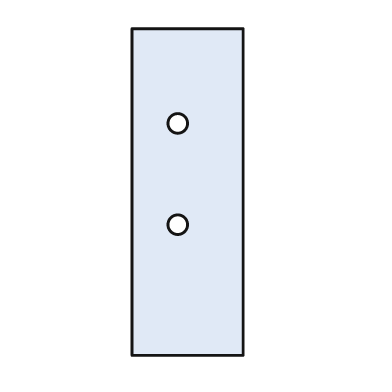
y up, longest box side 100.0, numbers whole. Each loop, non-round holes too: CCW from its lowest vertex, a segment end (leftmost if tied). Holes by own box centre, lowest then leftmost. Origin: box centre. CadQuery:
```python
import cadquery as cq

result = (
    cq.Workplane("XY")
    .moveTo(-17.0, -50.0)
    .lineTo(17.0, -50.0)
    .lineTo(17.0, 50.0)
    .lineTo(-17.0, 50.0)
    .close()
    .moveTo(-3.0, -10.0)
    .circle(3.0)
    .moveTo(-3.0, 21.0)
    .circle(3.0)
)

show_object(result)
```